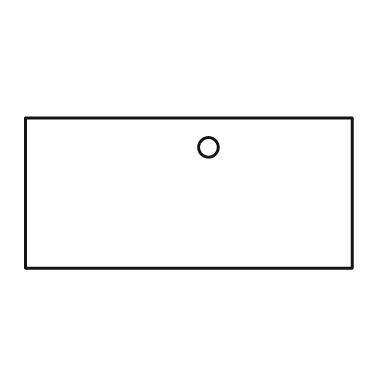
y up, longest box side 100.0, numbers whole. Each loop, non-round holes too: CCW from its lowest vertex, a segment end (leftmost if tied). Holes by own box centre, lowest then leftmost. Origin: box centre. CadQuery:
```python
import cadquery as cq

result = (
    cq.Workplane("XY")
    .moveTo(-50.0, -23.0)
    .lineTo(50.0, -23.0)
    .lineTo(50.0, 23.0)
    .lineTo(-50.0, 23.0)
    .close()
    .moveTo(6.0, 14.0)
    .circle(3.0)
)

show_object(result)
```